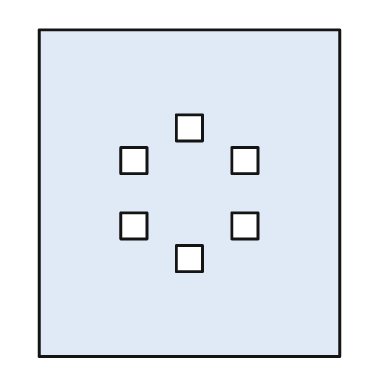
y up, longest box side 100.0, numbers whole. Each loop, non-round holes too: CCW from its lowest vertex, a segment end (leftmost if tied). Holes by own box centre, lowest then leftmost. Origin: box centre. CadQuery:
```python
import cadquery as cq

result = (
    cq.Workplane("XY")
    .moveTo(-46.0, -50.0)
    .lineTo(46.0, -50.0)
    .lineTo(46.0, 50.0)
    .lineTo(-46.0, 50.0)
    .close()
    .moveTo(-4.0, -24.0)
    .lineTo(4.0, -24.0)
    .lineTo(4.0, -16.0)
    .lineTo(-4.0, -16.0)
    .close()
    .moveTo(-21.0, -14.0)
    .lineTo(-13.0, -14.0)
    .lineTo(-13.0, -6.0)
    .lineTo(-21.0, -6.0)
    .close()
    .moveTo(13.0, -14.0)
    .lineTo(21.0, -14.0)
    .lineTo(21.0, -6.0)
    .lineTo(13.0, -6.0)
    .close()
    .moveTo(-21.0, 6.0)
    .lineTo(-13.0, 6.0)
    .lineTo(-13.0, 14.0)
    .lineTo(-21.0, 14.0)
    .close()
    .moveTo(13.0, 6.0)
    .lineTo(21.0, 6.0)
    .lineTo(21.0, 14.0)
    .lineTo(13.0, 14.0)
    .close()
    .moveTo(-4.0, 16.0)
    .lineTo(4.0, 16.0)
    .lineTo(4.0, 24.0)
    .lineTo(-4.0, 24.0)
    .close()
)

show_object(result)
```